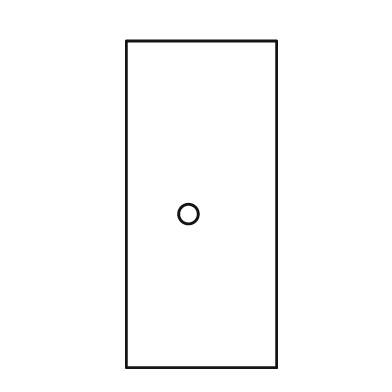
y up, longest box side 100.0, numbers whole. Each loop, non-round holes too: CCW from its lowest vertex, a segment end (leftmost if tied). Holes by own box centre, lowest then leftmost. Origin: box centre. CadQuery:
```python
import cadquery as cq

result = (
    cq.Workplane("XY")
    .moveTo(-23.0, -50.0)
    .lineTo(23.0, -50.0)
    .lineTo(23.0, 50.0)
    .lineTo(-23.0, 50.0)
    .close()
    .moveTo(-4.0, -3.0)
    .circle(3.0)
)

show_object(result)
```